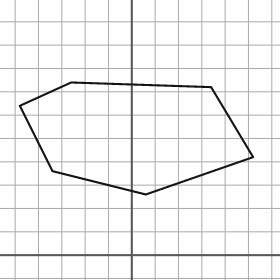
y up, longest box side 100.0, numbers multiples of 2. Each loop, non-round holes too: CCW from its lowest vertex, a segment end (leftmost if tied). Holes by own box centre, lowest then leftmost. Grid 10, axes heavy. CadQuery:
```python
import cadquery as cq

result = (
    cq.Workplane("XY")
    .moveTo(6.0, 26.0)
    .lineTo(52.0, 42.0)
    .lineTo(34.0, 72.0)
    .lineTo(-26.0, 74.0)
    .lineTo(-48.0, 64.0)
    .lineTo(-34.0, 36.0)
    .close()
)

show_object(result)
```